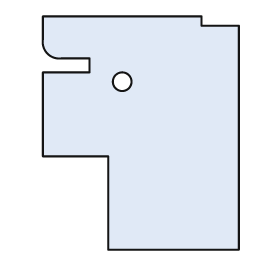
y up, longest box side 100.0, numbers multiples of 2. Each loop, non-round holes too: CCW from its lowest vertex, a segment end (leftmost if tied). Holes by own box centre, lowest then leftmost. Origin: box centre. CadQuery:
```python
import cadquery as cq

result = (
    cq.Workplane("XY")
    .moveTo(-14.0, -50.0)
    .lineTo(42.0, -50.0)
    .lineTo(42.0, 46.0)
    .lineTo(26.0, 46.0)
    .lineTo(26.0, 50.0)
    .lineTo(-42.0, 50.0)
    .lineTo(-42.0, 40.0)
    .threePointArc((-40.0, 34.0), (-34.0, 32.0))
    .lineTo(-22.0, 32.0)
    .lineTo(-22.0, 26.0)
    .lineTo(-42.0, 26.0)
    .lineTo(-42.0, -10.0)
    .lineTo(-14.0, -10.0)
    .close()
    .moveTo(-8.0, 22.0)
    .circle(4.0)
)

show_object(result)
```